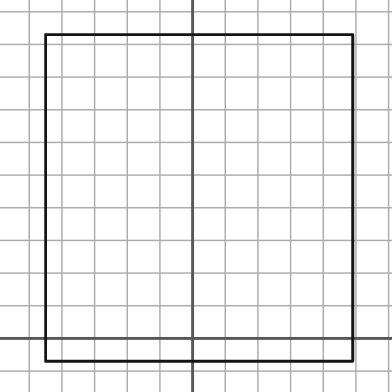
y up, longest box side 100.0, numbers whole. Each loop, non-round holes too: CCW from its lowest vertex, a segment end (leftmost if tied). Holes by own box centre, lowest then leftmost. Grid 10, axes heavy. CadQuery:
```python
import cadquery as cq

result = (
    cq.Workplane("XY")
    .moveTo(-45.0, -7.0)
    .lineTo(49.0, -7.0)
    .lineTo(49.0, 93.0)
    .lineTo(-45.0, 93.0)
    .close()
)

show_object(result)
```